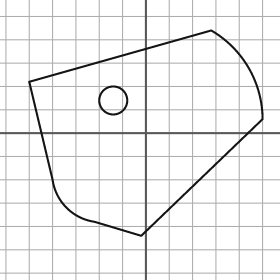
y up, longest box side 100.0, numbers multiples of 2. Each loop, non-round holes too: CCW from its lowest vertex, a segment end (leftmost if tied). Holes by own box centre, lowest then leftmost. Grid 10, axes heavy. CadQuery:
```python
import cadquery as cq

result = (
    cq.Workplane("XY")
    .moveTo(-2.0, -44.0)
    .lineTo(50.0, 6.0)
    .threePointArc((44.0, 28.0), (28.0, 44.0))
    .lineTo(-50.0, 22.0)
    .lineTo(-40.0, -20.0)
    .threePointArc((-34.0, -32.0), (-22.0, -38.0))
    .close()
    .moveTo(-14.0, 14.0)
    .circle(6.0)
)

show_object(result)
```